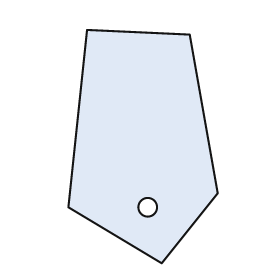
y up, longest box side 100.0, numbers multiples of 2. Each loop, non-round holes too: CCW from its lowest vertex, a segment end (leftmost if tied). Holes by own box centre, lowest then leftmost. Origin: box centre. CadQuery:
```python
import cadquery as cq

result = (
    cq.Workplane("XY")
    .moveTo(8.0, -50.0)
    .lineTo(32.0, -20.0)
    .lineTo(20.0, 48.0)
    .lineTo(-24.0, 50.0)
    .lineTo(-32.0, -26.0)
    .close()
    .moveTo(2.0, -26.0)
    .circle(4.0)
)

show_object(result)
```